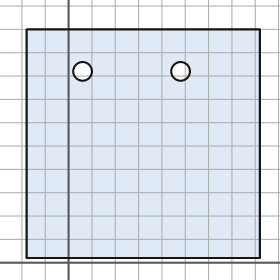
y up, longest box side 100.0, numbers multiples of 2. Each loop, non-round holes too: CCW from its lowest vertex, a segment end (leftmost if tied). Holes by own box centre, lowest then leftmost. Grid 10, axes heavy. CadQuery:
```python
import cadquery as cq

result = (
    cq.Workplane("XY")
    .moveTo(-18.0, 2.0)
    .lineTo(82.0, 2.0)
    .lineTo(82.0, 100.0)
    .lineTo(-18.0, 100.0)
    .close()
    .moveTo(6.0, 82.0)
    .circle(4.0)
    .moveTo(48.0, 82.0)
    .circle(4.0)
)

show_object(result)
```